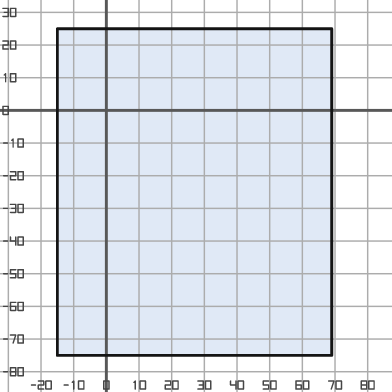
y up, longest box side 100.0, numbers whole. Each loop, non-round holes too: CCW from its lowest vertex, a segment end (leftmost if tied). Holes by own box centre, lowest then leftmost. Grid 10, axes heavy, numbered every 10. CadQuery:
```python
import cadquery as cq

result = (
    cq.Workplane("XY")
    .moveTo(-15.0, -75.0)
    .lineTo(69.0, -75.0)
    .lineTo(69.0, 25.0)
    .lineTo(-15.0, 25.0)
    .close()
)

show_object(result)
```